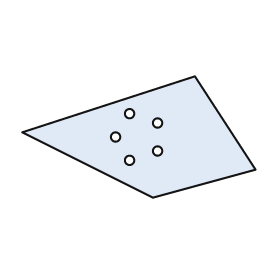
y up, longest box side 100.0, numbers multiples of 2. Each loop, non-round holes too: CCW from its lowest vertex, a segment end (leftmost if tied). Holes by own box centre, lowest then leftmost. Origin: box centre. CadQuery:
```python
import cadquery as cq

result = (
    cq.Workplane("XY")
    .moveTo(6.0, -26.0)
    .lineTo(50.0, -14.0)
    .lineTo(24.0, 26.0)
    .lineTo(-50.0, 2.0)
    .close()
    .moveTo(-4.0, -10.0)
    .circle(2.0)
    .moveTo(8.0, -6.0)
    .circle(2.0)
    .moveTo(-10.0, 0.0)
    .circle(2.0)
    .moveTo(8.0, 6.0)
    .circle(2.0)
    .moveTo(-4.0, 10.0)
    .circle(2.0)
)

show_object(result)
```